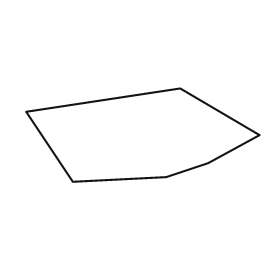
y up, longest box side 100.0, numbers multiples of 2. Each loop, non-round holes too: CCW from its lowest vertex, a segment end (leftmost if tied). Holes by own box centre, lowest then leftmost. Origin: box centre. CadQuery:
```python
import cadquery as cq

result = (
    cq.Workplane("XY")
    .moveTo(-30.0, -20.0)
    .lineTo(10.0, -18.0)
    .lineTo(28.0, -12.0)
    .lineTo(50.0, 0.0)
    .lineTo(16.0, 20.0)
    .lineTo(-50.0, 10.0)
    .close()
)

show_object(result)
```